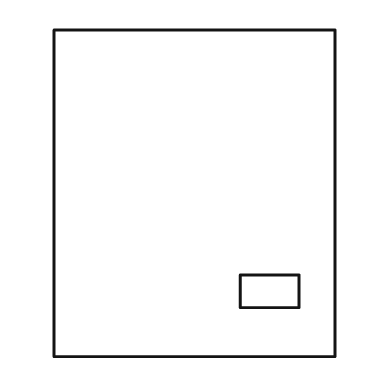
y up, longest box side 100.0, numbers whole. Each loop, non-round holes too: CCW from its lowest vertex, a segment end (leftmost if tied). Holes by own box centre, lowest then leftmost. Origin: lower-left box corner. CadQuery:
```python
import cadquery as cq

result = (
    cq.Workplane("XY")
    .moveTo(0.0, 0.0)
    .lineTo(86.0, 0.0)
    .lineTo(86.0, 100.0)
    .lineTo(0.0, 100.0)
    .close()
    .moveTo(57.0, 15.0)
    .lineTo(75.0, 15.0)
    .lineTo(75.0, 25.0)
    .lineTo(57.0, 25.0)
    .close()
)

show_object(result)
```